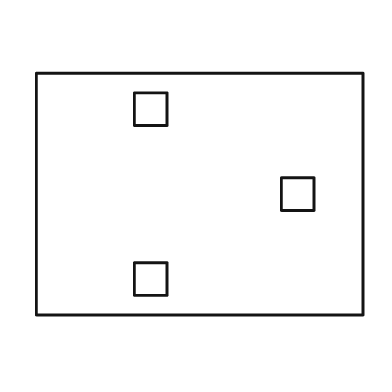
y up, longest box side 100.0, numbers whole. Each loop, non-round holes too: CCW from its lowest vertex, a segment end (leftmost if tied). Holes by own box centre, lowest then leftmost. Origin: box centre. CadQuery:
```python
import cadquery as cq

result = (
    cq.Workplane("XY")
    .moveTo(-50.0, -37.0)
    .lineTo(50.0, -37.0)
    .lineTo(50.0, 37.0)
    .lineTo(-50.0, 37.0)
    .close()
    .moveTo(-20.0, -31.0)
    .lineTo(-10.0, -31.0)
    .lineTo(-10.0, -21.0)
    .lineTo(-20.0, -21.0)
    .close()
    .moveTo(25.0, -5.0)
    .lineTo(35.0, -5.0)
    .lineTo(35.0, 5.0)
    .lineTo(25.0, 5.0)
    .close()
    .moveTo(-20.0, 21.0)
    .lineTo(-10.0, 21.0)
    .lineTo(-10.0, 31.0)
    .lineTo(-20.0, 31.0)
    .close()
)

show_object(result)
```